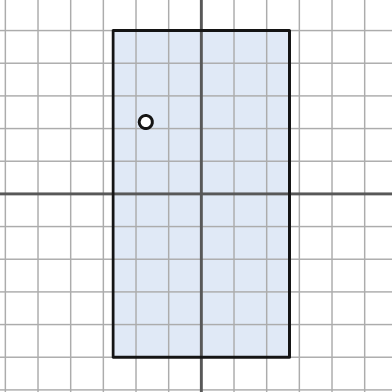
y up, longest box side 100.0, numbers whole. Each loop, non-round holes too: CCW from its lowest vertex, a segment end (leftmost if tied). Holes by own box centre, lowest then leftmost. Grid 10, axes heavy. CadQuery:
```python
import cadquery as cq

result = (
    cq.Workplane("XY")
    .moveTo(-27.0, -50.0)
    .lineTo(27.0, -50.0)
    .lineTo(27.0, 50.0)
    .lineTo(-27.0, 50.0)
    .close()
    .moveTo(-17.0, 22.0)
    .circle(2.0)
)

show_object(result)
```